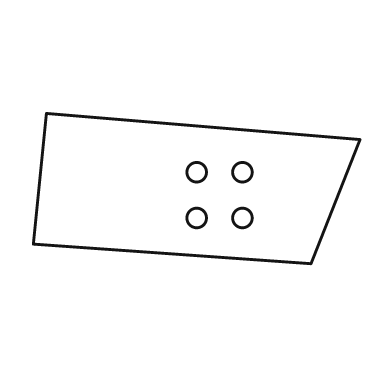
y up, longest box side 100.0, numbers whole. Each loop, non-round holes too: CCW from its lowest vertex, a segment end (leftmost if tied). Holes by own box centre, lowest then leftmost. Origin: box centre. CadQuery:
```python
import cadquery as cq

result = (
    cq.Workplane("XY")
    .moveTo(35.0, -23.0)
    .lineTo(50.0, 15.0)
    .lineTo(-46.0, 23.0)
    .lineTo(-50.0, -17.0)
    .close()
    .moveTo(0.0, -9.0)
    .circle(3.0)
    .moveTo(14.0, -9.0)
    .circle(3.0)
    .moveTo(0.0, 5.0)
    .circle(3.0)
    .moveTo(14.0, 5.0)
    .circle(3.0)
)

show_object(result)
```